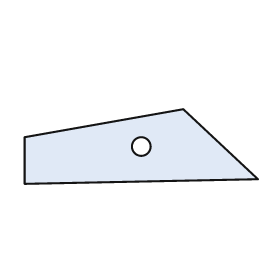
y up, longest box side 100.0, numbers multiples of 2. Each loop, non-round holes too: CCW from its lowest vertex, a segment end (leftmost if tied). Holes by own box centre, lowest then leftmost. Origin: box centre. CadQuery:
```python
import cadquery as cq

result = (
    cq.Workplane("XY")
    .moveTo(-50.0, -16.0)
    .lineTo(50.0, -14.0)
    .lineTo(18.0, 16.0)
    .lineTo(-50.0, 4.0)
    .close()
    .moveTo(0.0, 0.0)
    .circle(4.0)
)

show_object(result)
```